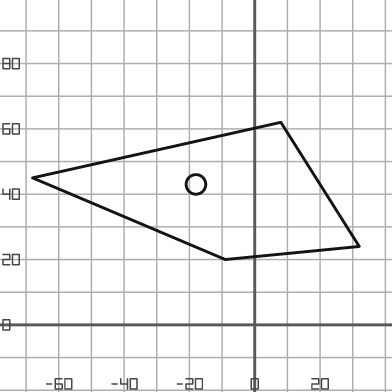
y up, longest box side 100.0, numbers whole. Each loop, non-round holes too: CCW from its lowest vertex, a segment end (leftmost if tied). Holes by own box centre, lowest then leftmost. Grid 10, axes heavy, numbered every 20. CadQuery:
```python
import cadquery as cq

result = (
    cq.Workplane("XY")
    .moveTo(-9.0, 20.0)
    .lineTo(32.0, 24.0)
    .lineTo(8.0, 62.0)
    .lineTo(-68.0, 45.0)
    .close()
    .moveTo(-18.0, 43.0)
    .circle(3.0)
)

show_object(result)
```